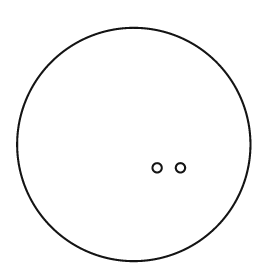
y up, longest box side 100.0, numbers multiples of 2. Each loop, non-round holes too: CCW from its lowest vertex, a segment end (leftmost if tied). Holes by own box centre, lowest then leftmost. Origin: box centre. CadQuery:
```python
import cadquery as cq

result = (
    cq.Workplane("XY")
    .moveTo(0.0, 0.0)
    .circle(50.0)
    .moveTo(10.0, -10.0)
    .circle(2.0)
    .moveTo(20.0, -10.0)
    .circle(2.0)
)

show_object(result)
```